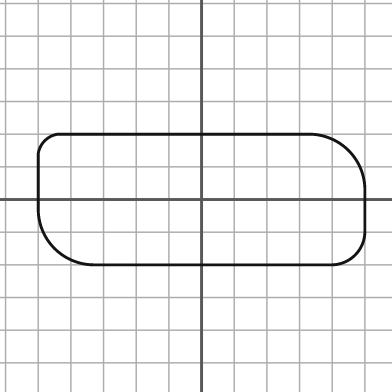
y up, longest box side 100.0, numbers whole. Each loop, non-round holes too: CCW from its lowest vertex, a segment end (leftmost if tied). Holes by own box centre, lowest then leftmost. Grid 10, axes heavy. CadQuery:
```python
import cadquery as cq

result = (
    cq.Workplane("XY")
    .moveTo(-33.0, -20.0)
    .lineTo(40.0, -20.0)
    .threePointArc((47.0, -17.0), (50.0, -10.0))
    .lineTo(50.0, 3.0)
    .threePointArc((45.0, 15.0), (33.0, 20.0))
    .lineTo(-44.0, 20.0)
    .threePointArc((-48.0, 18.0), (-50.0, 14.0))
    .lineTo(-50.0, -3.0)
    .threePointArc((-45.0, -15.0), (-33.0, -20.0))
    .close()
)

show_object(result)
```